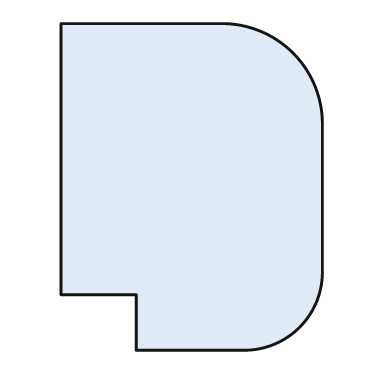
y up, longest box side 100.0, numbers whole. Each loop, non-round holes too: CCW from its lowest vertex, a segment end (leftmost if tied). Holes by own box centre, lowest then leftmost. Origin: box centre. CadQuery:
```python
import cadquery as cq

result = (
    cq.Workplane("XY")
    .moveTo(-17.0, -50.0)
    .lineTo(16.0, -50.0)
    .threePointArc((33.0, -43.0), (40.0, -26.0))
    .lineTo(40.0, 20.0)
    .threePointArc((31.0, 41.0), (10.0, 50.0))
    .lineTo(-40.0, 50.0)
    .lineTo(-40.0, -33.0)
    .lineTo(-17.0, -33.0)
    .close()
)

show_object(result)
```